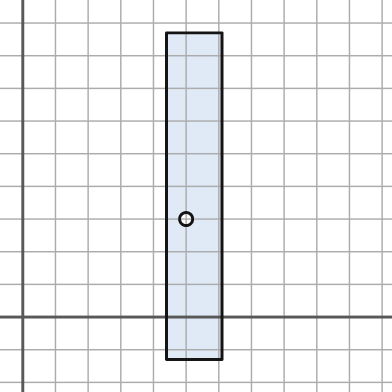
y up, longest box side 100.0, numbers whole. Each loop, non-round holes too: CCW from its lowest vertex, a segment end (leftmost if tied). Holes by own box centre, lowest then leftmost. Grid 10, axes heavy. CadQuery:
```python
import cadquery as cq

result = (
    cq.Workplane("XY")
    .moveTo(44.0, -13.0)
    .lineTo(61.0, -13.0)
    .lineTo(61.0, 87.0)
    .lineTo(44.0, 87.0)
    .close()
    .moveTo(50.0, 30.0)
    .circle(2.0)
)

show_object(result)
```